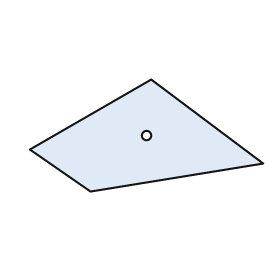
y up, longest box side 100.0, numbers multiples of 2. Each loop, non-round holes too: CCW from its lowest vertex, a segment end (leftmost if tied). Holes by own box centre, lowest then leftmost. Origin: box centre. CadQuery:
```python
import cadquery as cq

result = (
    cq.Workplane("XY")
    .moveTo(-24.0, -24.0)
    .lineTo(50.0, -12.0)
    .lineTo(2.0, 24.0)
    .lineTo(-50.0, -6.0)
    .close()
    .moveTo(0.0, 0.0)
    .circle(2.0)
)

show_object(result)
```